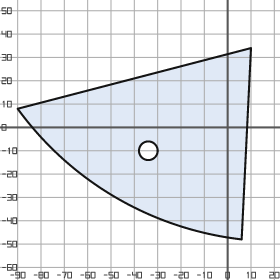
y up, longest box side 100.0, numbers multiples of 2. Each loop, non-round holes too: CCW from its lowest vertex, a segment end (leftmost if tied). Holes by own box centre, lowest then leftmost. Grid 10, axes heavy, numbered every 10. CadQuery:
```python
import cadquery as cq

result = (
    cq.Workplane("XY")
    .moveTo(6.0, -48.0)
    .lineTo(10.0, 34.0)
    .lineTo(-90.0, 8.0)
    .threePointArc((-48.0, -30.0), (6.0, -48.0))
    .close()
    .moveTo(-34.0, -10.0)
    .circle(4.0)
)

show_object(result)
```